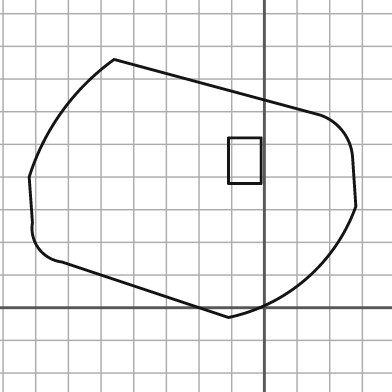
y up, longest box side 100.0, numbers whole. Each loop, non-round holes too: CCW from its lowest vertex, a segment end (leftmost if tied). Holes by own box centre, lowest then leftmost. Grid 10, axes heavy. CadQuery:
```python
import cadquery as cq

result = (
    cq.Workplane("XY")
    .moveTo(-11.0, -3.0)
    .threePointArc((13.0, 9.0), (28.0, 31.0))
    .lineTo(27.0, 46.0)
    .threePointArc((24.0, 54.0), (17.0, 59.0))
    .lineTo(-46.0, 76.0)
    .threePointArc((-62.0, 60.0), (-72.0, 40.0))
    .lineTo(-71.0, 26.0)
    .threePointArc((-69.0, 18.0), (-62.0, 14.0))
    .close()
    .moveTo(-11.0, 38.0)
    .lineTo(-1.0, 38.0)
    .lineTo(-1.0, 52.0)
    .lineTo(-11.0, 52.0)
    .close()
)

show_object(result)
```